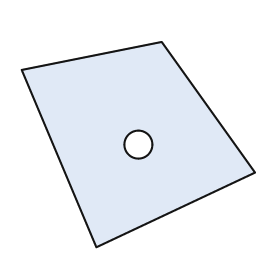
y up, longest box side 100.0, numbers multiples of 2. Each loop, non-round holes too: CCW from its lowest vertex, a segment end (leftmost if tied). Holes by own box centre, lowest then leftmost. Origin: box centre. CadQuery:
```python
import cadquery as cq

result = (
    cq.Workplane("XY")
    .moveTo(-18.0, -44.0)
    .lineTo(50.0, -12.0)
    .lineTo(10.0, 44.0)
    .lineTo(-50.0, 32.0)
    .close()
    .moveTo(0.0, 0.0)
    .circle(6.0)
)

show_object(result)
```